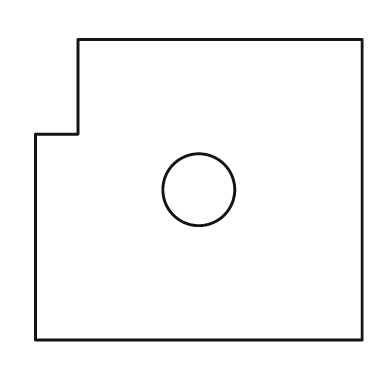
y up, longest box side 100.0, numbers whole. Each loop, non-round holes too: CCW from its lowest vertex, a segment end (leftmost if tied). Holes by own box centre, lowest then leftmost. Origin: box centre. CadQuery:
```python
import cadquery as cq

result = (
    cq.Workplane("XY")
    .moveTo(-50.0, -46.0)
    .lineTo(50.0, -46.0)
    .lineTo(50.0, 46.0)
    .lineTo(-37.0, 46.0)
    .lineTo(-37.0, 17.0)
    .lineTo(-50.0, 17.0)
    .close()
    .moveTo(0.0, 0.0)
    .circle(11.0)
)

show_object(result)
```